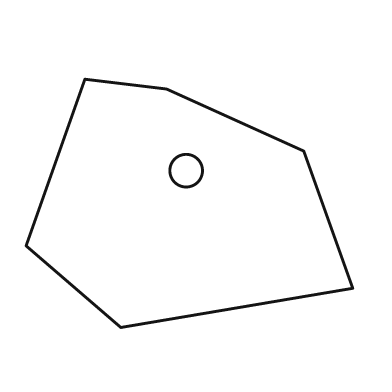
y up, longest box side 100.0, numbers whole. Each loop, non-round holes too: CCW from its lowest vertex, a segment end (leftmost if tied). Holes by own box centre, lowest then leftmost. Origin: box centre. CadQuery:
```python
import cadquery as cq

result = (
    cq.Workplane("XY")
    .moveTo(-21.0, -38.0)
    .lineTo(50.0, -26.0)
    .lineTo(35.0, 16.0)
    .lineTo(-7.0, 35.0)
    .lineTo(-32.0, 38.0)
    .lineTo(-50.0, -13.0)
    .close()
    .moveTo(-1.0, 10.0)
    .circle(5.0)
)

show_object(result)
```